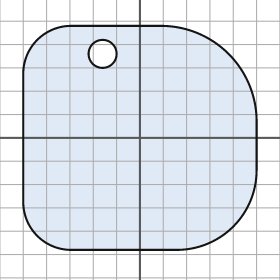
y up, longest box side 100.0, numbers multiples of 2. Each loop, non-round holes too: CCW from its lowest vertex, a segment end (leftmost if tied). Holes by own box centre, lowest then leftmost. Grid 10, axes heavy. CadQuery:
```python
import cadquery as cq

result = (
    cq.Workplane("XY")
    .moveTo(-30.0, -48.0)
    .lineTo(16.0, -48.0)
    .threePointArc((40.0, -38.0), (50.0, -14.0))
    .lineTo(50.0, 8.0)
    .threePointArc((38.0, 36.0), (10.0, 48.0))
    .lineTo(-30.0, 48.0)
    .threePointArc((-44.0, 42.0), (-50.0, 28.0))
    .lineTo(-50.0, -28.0)
    .threePointArc((-44.0, -42.0), (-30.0, -48.0))
    .close()
    .moveTo(-16.0, 36.0)
    .circle(6.0)
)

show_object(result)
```